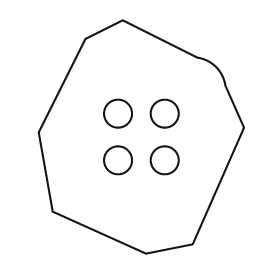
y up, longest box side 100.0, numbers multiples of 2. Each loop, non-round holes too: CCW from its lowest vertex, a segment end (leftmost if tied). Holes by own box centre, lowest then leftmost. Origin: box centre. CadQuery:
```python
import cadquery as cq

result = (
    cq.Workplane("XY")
    .moveTo(2.0, -50.0)
    .lineTo(22.0, -46.0)
    .lineTo(44.0, 4.0)
    .lineTo(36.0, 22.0)
    .threePointArc((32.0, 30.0), (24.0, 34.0))
    .lineTo(-8.0, 50.0)
    .lineTo(-24.0, 42.0)
    .lineTo(-44.0, 2.0)
    .lineTo(-38.0, -32.0)
    .close()
    .moveTo(-10.0, -10.0)
    .circle(6.0)
    .moveTo(10.0, -10.0)
    .circle(6.0)
    .moveTo(-10.0, 10.0)
    .circle(6.0)
    .moveTo(10.0, 10.0)
    .circle(6.0)
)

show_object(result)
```